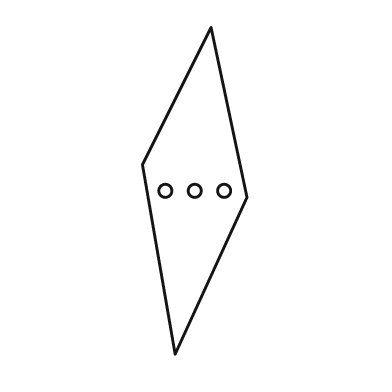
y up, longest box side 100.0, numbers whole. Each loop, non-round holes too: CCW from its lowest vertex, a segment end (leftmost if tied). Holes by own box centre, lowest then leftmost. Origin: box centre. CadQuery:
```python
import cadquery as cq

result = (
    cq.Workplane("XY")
    .moveTo(-6.0, -50.0)
    .lineTo(16.0, -2.0)
    .lineTo(5.0, 50.0)
    .lineTo(-16.0, 8.0)
    .close()
    .moveTo(-9.0, 0.0)
    .circle(2.0)
    .moveTo(0.0, 0.0)
    .circle(2.0)
    .moveTo(9.0, 0.0)
    .circle(2.0)
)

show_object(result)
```